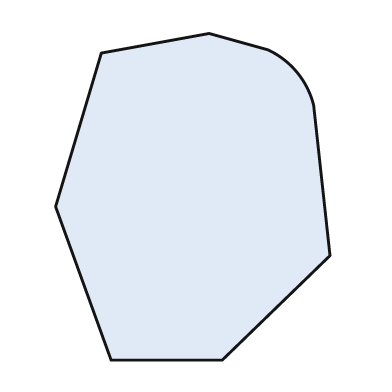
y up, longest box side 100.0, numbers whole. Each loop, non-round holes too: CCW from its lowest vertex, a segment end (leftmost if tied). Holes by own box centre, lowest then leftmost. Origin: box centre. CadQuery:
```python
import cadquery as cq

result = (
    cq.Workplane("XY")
    .moveTo(-25.0, -50.0)
    .lineTo(9.0, -50.0)
    .lineTo(42.0, -18.0)
    .lineTo(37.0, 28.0)
    .threePointArc((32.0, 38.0), (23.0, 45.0))
    .lineTo(5.0, 50.0)
    .lineTo(-28.0, 44.0)
    .lineTo(-42.0, -3.0)
    .close()
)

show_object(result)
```